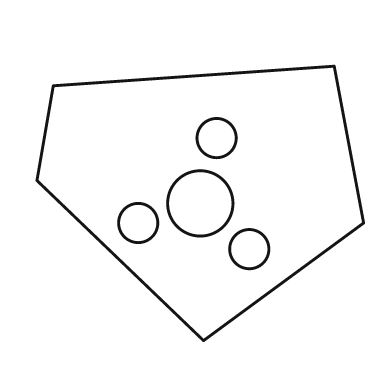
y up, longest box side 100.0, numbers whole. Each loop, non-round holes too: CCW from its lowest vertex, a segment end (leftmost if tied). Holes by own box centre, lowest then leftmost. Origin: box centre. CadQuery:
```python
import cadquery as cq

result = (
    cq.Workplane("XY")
    .moveTo(1.0, -42.0)
    .lineTo(50.0, -6.0)
    .lineTo(41.0, 42.0)
    .lineTo(-45.0, 36.0)
    .lineTo(-50.0, 7.0)
    .close()
    .moveTo(15.0, -14.0)
    .circle(6.0)
    .moveTo(-19.0, -6.0)
    .circle(6.0)
    .moveTo(0.0, 0.0)
    .circle(10.0)
    .moveTo(5.0, 20.0)
    .circle(6.0)
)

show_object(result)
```